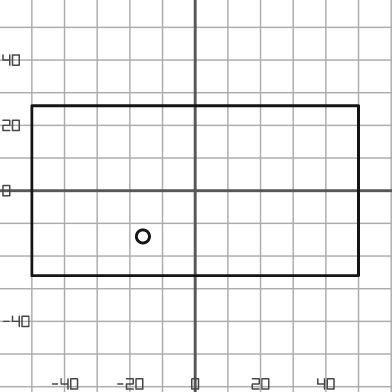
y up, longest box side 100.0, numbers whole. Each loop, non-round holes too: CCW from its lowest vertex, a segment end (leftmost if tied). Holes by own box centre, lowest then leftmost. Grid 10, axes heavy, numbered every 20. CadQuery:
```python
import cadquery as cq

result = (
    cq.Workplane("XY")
    .moveTo(-50.0, -26.0)
    .lineTo(50.0, -26.0)
    .lineTo(50.0, 26.0)
    .lineTo(-50.0, 26.0)
    .close()
    .moveTo(-16.0, -14.0)
    .circle(2.0)
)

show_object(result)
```